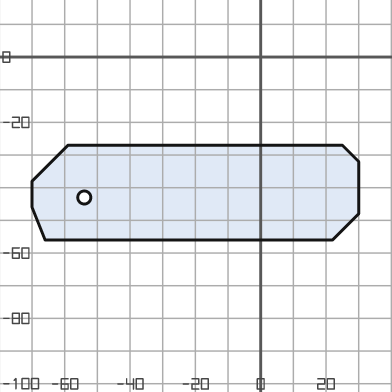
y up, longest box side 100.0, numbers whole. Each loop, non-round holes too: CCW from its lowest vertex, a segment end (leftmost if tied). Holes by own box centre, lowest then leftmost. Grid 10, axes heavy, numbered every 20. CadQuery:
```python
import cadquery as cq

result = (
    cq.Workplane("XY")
    .moveTo(-66.0, -56.0)
    .lineTo(22.0, -56.0)
    .lineTo(30.0, -48.0)
    .lineTo(30.0, -32.0)
    .lineTo(25.0, -27.0)
    .lineTo(-59.0, -27.0)
    .lineTo(-70.0, -38.0)
    .lineTo(-70.0, -46.0)
    .close()
    .moveTo(-54.0, -43.0)
    .circle(2.0)
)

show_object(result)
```